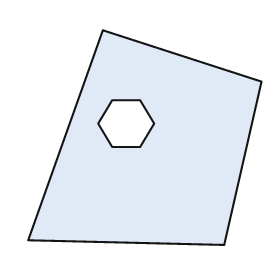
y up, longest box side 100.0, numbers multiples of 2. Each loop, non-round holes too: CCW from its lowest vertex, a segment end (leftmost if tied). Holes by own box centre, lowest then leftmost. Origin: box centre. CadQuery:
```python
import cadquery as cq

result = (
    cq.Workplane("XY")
    .moveTo(34.0, -46.0)
    .lineTo(50.0, 24.0)
    .lineTo(-18.0, 46.0)
    .lineTo(-50.0, -44.0)
    .close()
    .moveTo(-14.0, -4.0)
    .lineTo(-2.0, -4.0)
    .lineTo(4.0, 6.0)
    .lineTo(-2.0, 16.0)
    .lineTo(-14.0, 16.0)
    .lineTo(-20.0, 6.0)
    .close()
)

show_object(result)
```